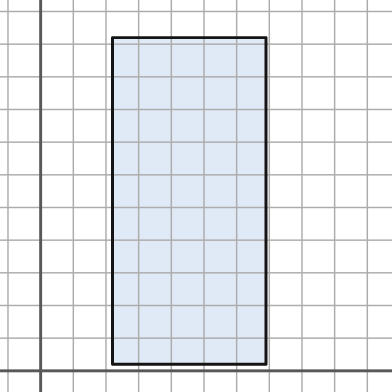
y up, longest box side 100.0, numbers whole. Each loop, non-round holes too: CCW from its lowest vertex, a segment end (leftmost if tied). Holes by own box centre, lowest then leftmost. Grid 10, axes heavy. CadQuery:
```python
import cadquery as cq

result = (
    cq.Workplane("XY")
    .moveTo(22.0, 2.0)
    .lineTo(69.0, 2.0)
    .lineTo(69.0, 102.0)
    .lineTo(22.0, 102.0)
    .close()
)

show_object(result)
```